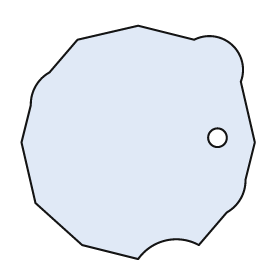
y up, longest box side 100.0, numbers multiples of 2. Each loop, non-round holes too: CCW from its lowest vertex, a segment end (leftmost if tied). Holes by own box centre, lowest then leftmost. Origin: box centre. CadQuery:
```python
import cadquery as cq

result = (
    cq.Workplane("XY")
    .moveTo(0.0, -50.0)
    .threePointArc((12.0, -42.0), (26.0, -44.0))
    .lineTo(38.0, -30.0)
    .threePointArc((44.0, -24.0), (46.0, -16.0))
    .lineTo(50.0, 0.0)
    .lineTo(44.0, 26.0)
    .threePointArc((40.0, 42.0), (24.0, 44.0))
    .lineTo(0.0, 50.0)
    .lineTo(-26.0, 44.0)
    .lineTo(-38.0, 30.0)
    .threePointArc((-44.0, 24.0), (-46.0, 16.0))
    .lineTo(-50.0, 0.0)
    .lineTo(-44.0, -26.0)
    .lineTo(-24.0, -44.0)
    .close()
    .moveTo(34.0, 2.0)
    .circle(4.0)
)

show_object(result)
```